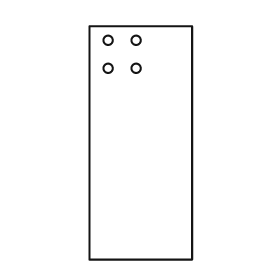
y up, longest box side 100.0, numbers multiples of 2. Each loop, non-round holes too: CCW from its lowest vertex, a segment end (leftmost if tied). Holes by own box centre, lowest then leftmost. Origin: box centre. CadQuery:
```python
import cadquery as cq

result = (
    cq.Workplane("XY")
    .moveTo(-22.0, -50.0)
    .lineTo(22.0, -50.0)
    .lineTo(22.0, 50.0)
    .lineTo(-22.0, 50.0)
    .close()
    .moveTo(-14.0, 32.0)
    .circle(2.0)
    .moveTo(-2.0, 32.0)
    .circle(2.0)
    .moveTo(-14.0, 44.0)
    .circle(2.0)
    .moveTo(-2.0, 44.0)
    .circle(2.0)
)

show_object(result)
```